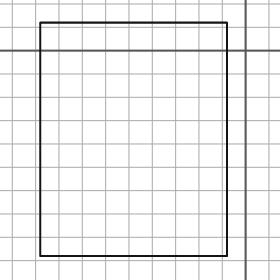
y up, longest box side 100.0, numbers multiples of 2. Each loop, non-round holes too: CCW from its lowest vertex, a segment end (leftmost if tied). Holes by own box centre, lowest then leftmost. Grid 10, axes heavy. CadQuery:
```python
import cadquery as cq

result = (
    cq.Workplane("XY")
    .moveTo(-88.0, -88.0)
    .lineTo(-8.0, -88.0)
    .lineTo(-8.0, 12.0)
    .lineTo(-88.0, 12.0)
    .close()
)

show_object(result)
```